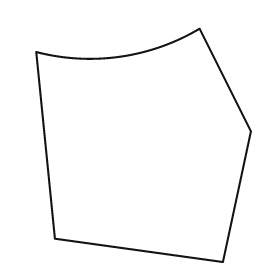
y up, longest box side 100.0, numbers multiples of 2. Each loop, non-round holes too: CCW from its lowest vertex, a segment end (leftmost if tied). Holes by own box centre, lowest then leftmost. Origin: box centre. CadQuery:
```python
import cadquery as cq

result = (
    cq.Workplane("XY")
    .moveTo(34.0, -50.0)
    .lineTo(46.0, 6.0)
    .lineTo(24.0, 50.0)
    .threePointArc((-10.0, 38.0), (-46.0, 40.0))
    .lineTo(-38.0, -40.0)
    .close()
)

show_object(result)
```